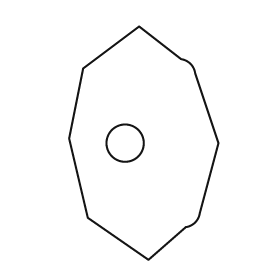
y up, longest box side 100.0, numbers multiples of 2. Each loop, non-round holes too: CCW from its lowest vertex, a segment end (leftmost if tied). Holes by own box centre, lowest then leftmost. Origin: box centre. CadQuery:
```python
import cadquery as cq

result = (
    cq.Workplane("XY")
    .moveTo(2.0, -50.0)
    .lineTo(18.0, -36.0)
    .threePointArc((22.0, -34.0), (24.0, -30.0))
    .lineTo(32.0, 0.0)
    .lineTo(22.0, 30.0)
    .threePointArc((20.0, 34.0), (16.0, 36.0))
    .lineTo(-2.0, 50.0)
    .lineTo(-26.0, 32.0)
    .lineTo(-32.0, 2.0)
    .lineTo(-24.0, -32.0)
    .close()
    .moveTo(-8.0, 0.0)
    .circle(8.0)
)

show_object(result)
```